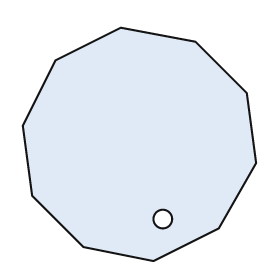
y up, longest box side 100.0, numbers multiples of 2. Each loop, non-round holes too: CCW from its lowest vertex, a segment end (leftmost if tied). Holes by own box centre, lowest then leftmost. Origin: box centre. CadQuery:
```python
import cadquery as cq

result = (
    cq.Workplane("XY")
    .moveTo(6.0, -50.0)
    .lineTo(34.0, -36.0)
    .lineTo(50.0, -8.0)
    .lineTo(46.0, 22.0)
    .lineTo(24.0, 44.0)
    .lineTo(-8.0, 50.0)
    .lineTo(-36.0, 36.0)
    .lineTo(-50.0, 8.0)
    .lineTo(-46.0, -22.0)
    .lineTo(-24.0, -44.0)
    .close()
    .moveTo(10.0, -32.0)
    .circle(4.0)
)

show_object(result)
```